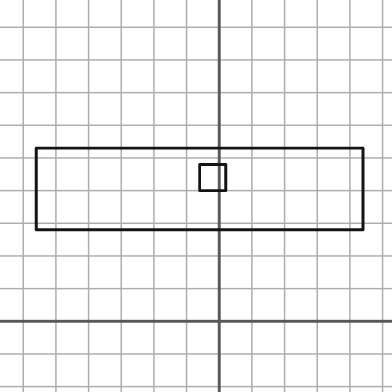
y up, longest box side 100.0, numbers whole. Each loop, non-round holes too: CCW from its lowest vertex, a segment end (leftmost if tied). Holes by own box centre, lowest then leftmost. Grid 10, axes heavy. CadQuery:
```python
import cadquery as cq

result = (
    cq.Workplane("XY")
    .moveTo(-56.0, 28.0)
    .lineTo(44.0, 28.0)
    .lineTo(44.0, 53.0)
    .lineTo(-56.0, 53.0)
    .close()
    .moveTo(-6.0, 40.0)
    .lineTo(2.0, 40.0)
    .lineTo(2.0, 48.0)
    .lineTo(-6.0, 48.0)
    .close()
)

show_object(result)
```